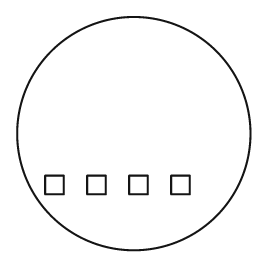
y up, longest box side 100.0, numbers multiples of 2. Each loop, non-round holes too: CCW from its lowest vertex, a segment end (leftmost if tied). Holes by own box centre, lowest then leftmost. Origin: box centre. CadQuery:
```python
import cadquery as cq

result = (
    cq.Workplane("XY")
    .moveTo(0.0, 0.0)
    .circle(50.0)
    .moveTo(-38.0, -26.0)
    .lineTo(-30.0, -26.0)
    .lineTo(-30.0, -18.0)
    .lineTo(-38.0, -18.0)
    .close()
    .moveTo(-20.0, -26.0)
    .lineTo(-12.0, -26.0)
    .lineTo(-12.0, -18.0)
    .lineTo(-20.0, -18.0)
    .close()
    .moveTo(-2.0, -26.0)
    .lineTo(6.0, -26.0)
    .lineTo(6.0, -18.0)
    .lineTo(-2.0, -18.0)
    .close()
    .moveTo(16.0, -26.0)
    .lineTo(24.0, -26.0)
    .lineTo(24.0, -18.0)
    .lineTo(16.0, -18.0)
    .close()
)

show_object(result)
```